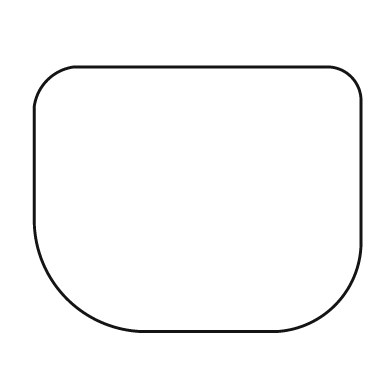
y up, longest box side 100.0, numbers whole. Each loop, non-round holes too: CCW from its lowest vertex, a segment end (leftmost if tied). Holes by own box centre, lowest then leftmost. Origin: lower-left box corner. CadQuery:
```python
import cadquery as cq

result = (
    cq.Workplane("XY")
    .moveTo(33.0, 0.0)
    .lineTo(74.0, 0.0)
    .threePointArc((92.0, 8.0), (100.0, 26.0))
    .lineTo(100.0, 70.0)
    .threePointArc((97.0, 78.0), (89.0, 81.0))
    .lineTo(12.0, 81.0)
    .threePointArc((4.0, 77.0), (0.0, 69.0))
    .lineTo(0.0, 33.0)
    .threePointArc((10.0, 10.0), (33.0, 0.0))
    .close()
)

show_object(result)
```